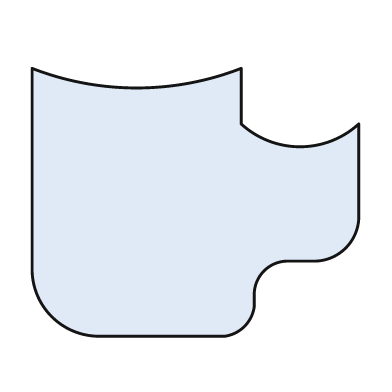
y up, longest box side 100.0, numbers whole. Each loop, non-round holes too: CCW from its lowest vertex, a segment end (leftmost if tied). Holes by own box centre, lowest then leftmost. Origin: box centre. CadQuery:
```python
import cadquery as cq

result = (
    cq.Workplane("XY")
    .moveTo(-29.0, -41.0)
    .lineTo(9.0, -41.0)
    .threePointArc((15.0, -38.0), (18.0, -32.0))
    .lineTo(18.0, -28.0)
    .threePointArc((21.0, -21.0), (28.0, -18.0))
    .lineTo(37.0, -18.0)
    .threePointArc((46.0, -14.0), (50.0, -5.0))
    .lineTo(50.0, 24.0)
    .threePointArc((32.0, 17.0), (14.0, 24.0))
    .lineTo(14.0, 41.0)
    .threePointArc((-18.0, 35.0), (-50.0, 41.0))
    .lineTo(-50.0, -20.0)
    .threePointArc((-44.0, -35.0), (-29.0, -41.0))
    .close()
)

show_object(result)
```